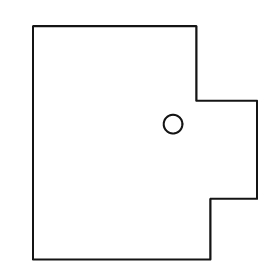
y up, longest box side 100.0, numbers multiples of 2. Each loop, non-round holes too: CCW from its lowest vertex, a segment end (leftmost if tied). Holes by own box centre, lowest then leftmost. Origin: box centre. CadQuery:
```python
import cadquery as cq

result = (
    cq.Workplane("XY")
    .moveTo(-48.0, -50.0)
    .lineTo(28.0, -50.0)
    .lineTo(28.0, -24.0)
    .lineTo(48.0, -24.0)
    .lineTo(48.0, 18.0)
    .lineTo(22.0, 18.0)
    .lineTo(22.0, 50.0)
    .lineTo(-48.0, 50.0)
    .close()
    .moveTo(12.0, 8.0)
    .circle(4.0)
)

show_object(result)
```